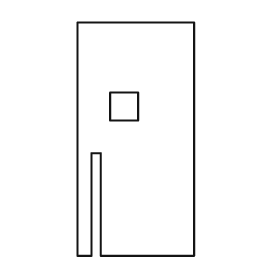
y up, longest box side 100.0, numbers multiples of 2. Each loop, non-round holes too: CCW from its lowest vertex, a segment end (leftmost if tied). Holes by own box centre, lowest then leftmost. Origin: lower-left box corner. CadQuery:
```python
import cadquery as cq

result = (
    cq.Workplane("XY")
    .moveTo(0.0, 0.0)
    .lineTo(6.0, 0.0)
    .lineTo(6.0, 44.0)
    .lineTo(10.0, 44.0)
    .lineTo(10.0, 0.0)
    .lineTo(50.0, 0.0)
    .lineTo(50.0, 100.0)
    .lineTo(0.0, 100.0)
    .close()
    .moveTo(14.0, 58.0)
    .lineTo(26.0, 58.0)
    .lineTo(26.0, 70.0)
    .lineTo(14.0, 70.0)
    .close()
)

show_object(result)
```